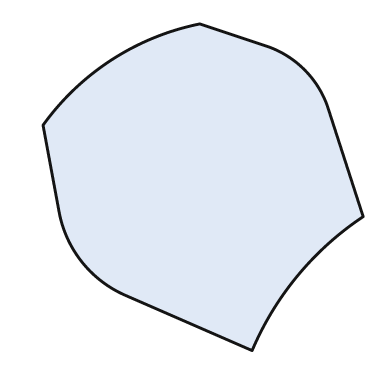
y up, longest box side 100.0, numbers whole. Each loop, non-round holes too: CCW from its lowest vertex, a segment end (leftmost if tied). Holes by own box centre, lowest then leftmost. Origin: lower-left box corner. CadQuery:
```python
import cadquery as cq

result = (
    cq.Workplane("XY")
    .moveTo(64.0, 0.0)
    .threePointArc((78.0, 23.0), (98.0, 41.0))
    .lineTo(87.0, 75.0)
    .threePointArc((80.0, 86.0), (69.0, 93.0))
    .lineTo(48.0, 100.0)
    .threePointArc((21.0, 89.0), (0.0, 69.0))
    .lineTo(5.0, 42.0)
    .threePointArc((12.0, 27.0), (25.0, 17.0))
    .close()
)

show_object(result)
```